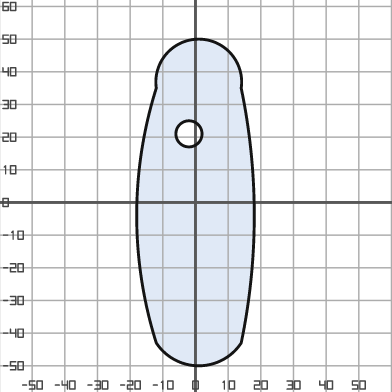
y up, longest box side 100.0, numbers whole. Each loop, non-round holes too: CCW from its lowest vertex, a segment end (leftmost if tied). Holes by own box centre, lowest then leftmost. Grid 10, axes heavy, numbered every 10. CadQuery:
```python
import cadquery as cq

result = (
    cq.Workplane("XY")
    .moveTo(-12.0, -43.0)
    .threePointArc((1.0, -50.0), (14.0, -43.0))
    .threePointArc((18.0, -4.0), (14.0, 35.0))
    .threePointArc((1.0, 50.0), (-12.0, 35.0))
    .threePointArc((-18.0, -4.0), (-12.0, -43.0))
    .close()
    .moveTo(-2.0, 21.0)
    .circle(4.0)
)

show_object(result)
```